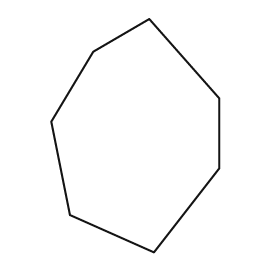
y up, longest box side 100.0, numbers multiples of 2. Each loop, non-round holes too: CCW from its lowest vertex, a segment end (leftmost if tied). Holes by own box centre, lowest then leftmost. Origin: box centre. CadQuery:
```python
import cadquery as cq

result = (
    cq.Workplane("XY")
    .moveTo(8.0, -50.0)
    .lineTo(36.0, -14.0)
    .lineTo(36.0, 16.0)
    .lineTo(6.0, 50.0)
    .lineTo(-18.0, 36.0)
    .lineTo(-36.0, 6.0)
    .lineTo(-28.0, -34.0)
    .close()
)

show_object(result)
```